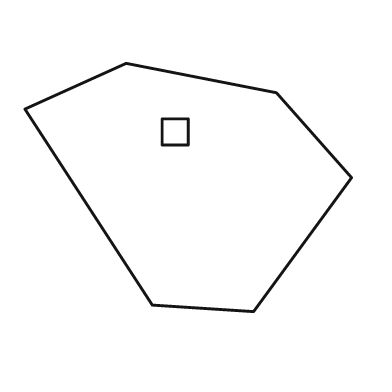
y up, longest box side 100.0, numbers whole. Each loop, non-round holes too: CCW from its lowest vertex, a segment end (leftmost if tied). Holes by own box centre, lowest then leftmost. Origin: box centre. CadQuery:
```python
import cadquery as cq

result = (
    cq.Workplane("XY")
    .moveTo(20.0, -38.0)
    .lineTo(50.0, 3.0)
    .lineTo(27.0, 29.0)
    .lineTo(-19.0, 38.0)
    .lineTo(-50.0, 24.0)
    .lineTo(-11.0, -36.0)
    .close()
    .moveTo(-8.0, 13.0)
    .lineTo(0.0, 13.0)
    .lineTo(0.0, 21.0)
    .lineTo(-8.0, 21.0)
    .close()
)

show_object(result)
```